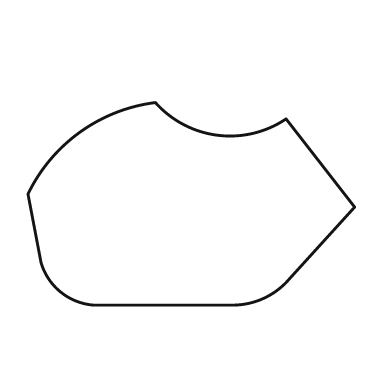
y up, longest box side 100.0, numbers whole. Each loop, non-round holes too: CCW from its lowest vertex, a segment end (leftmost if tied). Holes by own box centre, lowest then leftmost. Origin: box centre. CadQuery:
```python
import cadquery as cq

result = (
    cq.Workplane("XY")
    .moveTo(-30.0, -31.0)
    .lineTo(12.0, -31.0)
    .threePointArc((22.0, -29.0), (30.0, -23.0))
    .lineTo(50.0, -1.0)
    .lineTo(29.0, 26.0)
    .threePointArc((8.0, 21.0), (-11.0, 31.0))
    .threePointArc((-34.0, 22.0), (-50.0, 3.0))
    .lineTo(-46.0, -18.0)
    .threePointArc((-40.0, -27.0), (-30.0, -31.0))
    .close()
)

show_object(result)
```